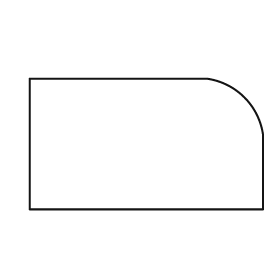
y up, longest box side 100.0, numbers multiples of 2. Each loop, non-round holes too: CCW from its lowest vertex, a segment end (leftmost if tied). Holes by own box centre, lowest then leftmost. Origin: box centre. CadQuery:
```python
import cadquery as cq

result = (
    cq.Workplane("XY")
    .moveTo(-50.0, -28.0)
    .lineTo(50.0, -28.0)
    .lineTo(50.0, 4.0)
    .threePointArc((42.0, 20.0), (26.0, 28.0))
    .lineTo(-50.0, 28.0)
    .close()
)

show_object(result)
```